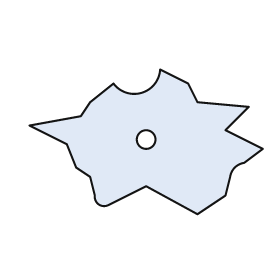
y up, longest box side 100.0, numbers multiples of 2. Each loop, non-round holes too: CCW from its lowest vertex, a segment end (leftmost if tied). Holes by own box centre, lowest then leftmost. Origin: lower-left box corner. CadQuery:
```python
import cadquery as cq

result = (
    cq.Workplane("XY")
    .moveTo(72.0, 0.0)
    .lineTo(84.0, 8.0)
    .lineTo(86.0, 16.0)
    .threePointArc((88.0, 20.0), (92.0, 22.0))
    .lineTo(100.0, 28.0)
    .lineTo(84.0, 36.0)
    .lineTo(94.0, 46.0)
    .lineTo(72.0, 48.0)
    .lineTo(68.0, 56.0)
    .lineTo(56.0, 62.0)
    .threePointArc((48.0, 52.0), (36.0, 56.0))
    .lineTo(26.0, 48.0)
    .lineTo(22.0, 42.0)
    .lineTo(0.0, 38.0)
    .lineTo(16.0, 30.0)
    .lineTo(20.0, 20.0)
    .lineTo(26.0, 16.0)
    .lineTo(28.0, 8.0)
    .threePointArc((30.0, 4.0), (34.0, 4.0))
    .lineTo(50.0, 12.0)
    .close()
    .moveTo(50.0, 32.0)
    .circle(4.0)
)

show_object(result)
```